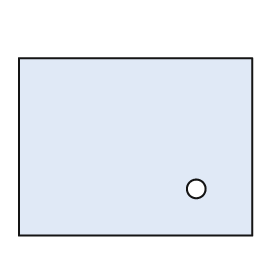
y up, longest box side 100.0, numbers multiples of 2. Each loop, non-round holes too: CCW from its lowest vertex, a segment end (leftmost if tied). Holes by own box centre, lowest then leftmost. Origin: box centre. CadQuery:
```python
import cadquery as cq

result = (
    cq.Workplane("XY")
    .moveTo(-50.0, -38.0)
    .lineTo(50.0, -38.0)
    .lineTo(50.0, 38.0)
    .lineTo(-50.0, 38.0)
    .close()
    .moveTo(26.0, -18.0)
    .circle(4.0)
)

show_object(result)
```